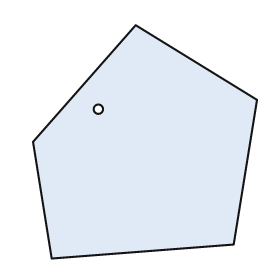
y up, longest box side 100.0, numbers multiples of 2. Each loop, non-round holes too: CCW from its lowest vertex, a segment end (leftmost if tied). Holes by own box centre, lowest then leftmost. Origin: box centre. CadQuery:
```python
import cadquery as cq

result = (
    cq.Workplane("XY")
    .moveTo(-40.0, -50.0)
    .lineTo(38.0, -44.0)
    .lineTo(48.0, 18.0)
    .lineTo(-4.0, 50.0)
    .lineTo(-48.0, 0.0)
    .close()
    .moveTo(-20.0, 14.0)
    .circle(2.0)
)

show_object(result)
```